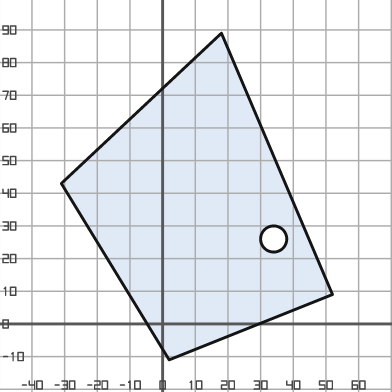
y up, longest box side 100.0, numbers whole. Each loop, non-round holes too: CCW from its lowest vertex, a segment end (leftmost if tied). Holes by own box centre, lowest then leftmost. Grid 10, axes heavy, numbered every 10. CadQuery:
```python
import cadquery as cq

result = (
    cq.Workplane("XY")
    .moveTo(2.0, -11.0)
    .lineTo(52.0, 9.0)
    .lineTo(18.0, 89.0)
    .lineTo(-31.0, 43.0)
    .close()
    .moveTo(34.0, 26.0)
    .circle(4.0)
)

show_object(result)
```